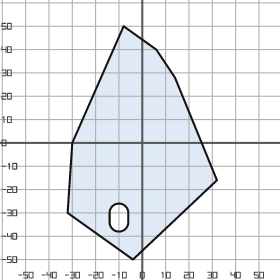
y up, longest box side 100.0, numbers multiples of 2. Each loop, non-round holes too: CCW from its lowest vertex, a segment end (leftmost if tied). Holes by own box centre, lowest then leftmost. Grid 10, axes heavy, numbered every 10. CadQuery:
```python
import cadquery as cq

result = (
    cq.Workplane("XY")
    .moveTo(-4.0, -50.0)
    .lineTo(32.0, -16.0)
    .lineTo(14.0, 28.0)
    .lineTo(6.0, 40.0)
    .lineTo(-8.0, 50.0)
    .lineTo(-30.0, 0.0)
    .lineTo(-32.0, -30.0)
    .close()
    .moveTo(-14.0, -34.0)
    .threePointArc((-10.0, -38.0), (-6.0, -34.0))
    .lineTo(-6.0, -30.0)
    .threePointArc((-10.0, -26.0), (-14.0, -30.0))
    .close()
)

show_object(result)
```